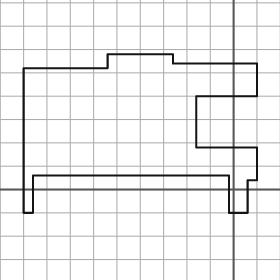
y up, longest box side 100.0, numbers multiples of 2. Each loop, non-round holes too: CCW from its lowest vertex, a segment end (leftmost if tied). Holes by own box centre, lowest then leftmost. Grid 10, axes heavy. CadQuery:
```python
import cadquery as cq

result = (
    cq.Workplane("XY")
    .moveTo(-90.0, -10.0)
    .lineTo(-86.0, -10.0)
    .lineTo(-86.0, 6.0)
    .lineTo(-2.0, 6.0)
    .lineTo(-2.0, -10.0)
    .lineTo(6.0, -10.0)
    .lineTo(6.0, 4.0)
    .lineTo(10.0, 4.0)
    .lineTo(10.0, 18.0)
    .lineTo(-16.0, 18.0)
    .lineTo(-16.0, 40.0)
    .lineTo(10.0, 40.0)
    .lineTo(10.0, 54.0)
    .lineTo(-26.0, 54.0)
    .lineTo(-26.0, 58.0)
    .lineTo(-54.0, 58.0)
    .lineTo(-54.0, 52.0)
    .lineTo(-90.0, 52.0)
    .close()
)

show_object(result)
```